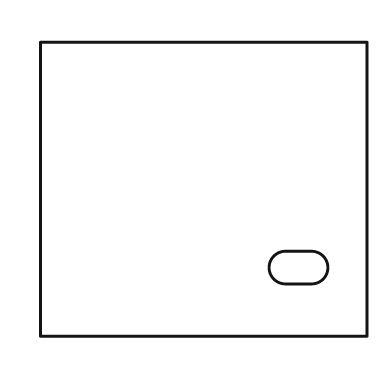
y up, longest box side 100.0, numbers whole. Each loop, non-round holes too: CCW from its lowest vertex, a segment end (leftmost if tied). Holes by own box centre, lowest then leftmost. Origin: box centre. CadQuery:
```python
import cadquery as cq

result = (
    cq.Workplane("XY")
    .moveTo(-50.0, -45.0)
    .lineTo(50.0, -45.0)
    .lineTo(50.0, 45.0)
    .lineTo(-50.0, 45.0)
    .close()
    .moveTo(25.0, -29.0)
    .lineTo(33.0, -29.0)
    .threePointArc((38.0, -24.0), (33.0, -19.0))
    .lineTo(25.0, -19.0)
    .threePointArc((20.0, -24.0), (25.0, -29.0))
    .close()
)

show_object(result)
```